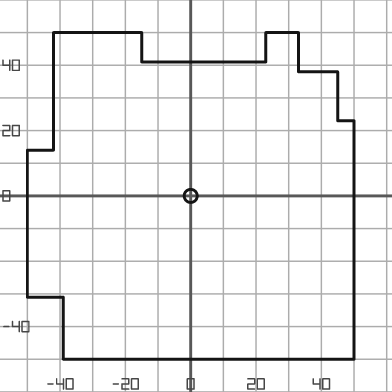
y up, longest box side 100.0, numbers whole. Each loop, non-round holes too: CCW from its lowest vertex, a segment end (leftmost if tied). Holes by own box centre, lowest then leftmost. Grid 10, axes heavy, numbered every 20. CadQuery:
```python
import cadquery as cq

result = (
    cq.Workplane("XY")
    .moveTo(-39.0, -50.0)
    .lineTo(50.0, -50.0)
    .lineTo(50.0, 23.0)
    .lineTo(45.0, 23.0)
    .lineTo(45.0, 38.0)
    .lineTo(33.0, 38.0)
    .lineTo(33.0, 50.0)
    .lineTo(23.0, 50.0)
    .lineTo(23.0, 41.0)
    .lineTo(-15.0, 41.0)
    .lineTo(-15.0, 50.0)
    .lineTo(-42.0, 50.0)
    .lineTo(-42.0, 14.0)
    .lineTo(-50.0, 14.0)
    .lineTo(-50.0, -31.0)
    .lineTo(-39.0, -31.0)
    .close()
    .moveTo(0.0, 0.0)
    .circle(2.0)
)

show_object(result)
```